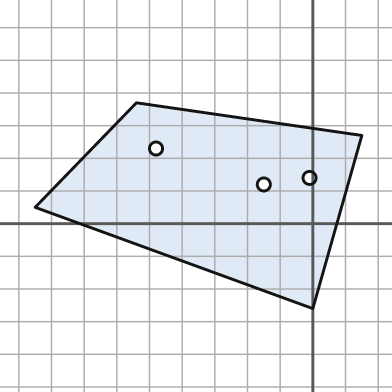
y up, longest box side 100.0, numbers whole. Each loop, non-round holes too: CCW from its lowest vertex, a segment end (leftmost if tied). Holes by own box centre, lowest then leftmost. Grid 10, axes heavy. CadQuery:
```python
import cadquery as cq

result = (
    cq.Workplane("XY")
    .moveTo(0.0, -26.0)
    .lineTo(15.0, 27.0)
    .lineTo(-54.0, 37.0)
    .lineTo(-85.0, 5.0)
    .close()
    .moveTo(-15.0, 12.0)
    .circle(2.0)
    .moveTo(-1.0, 14.0)
    .circle(2.0)
    .moveTo(-48.0, 23.0)
    .circle(2.0)
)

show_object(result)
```